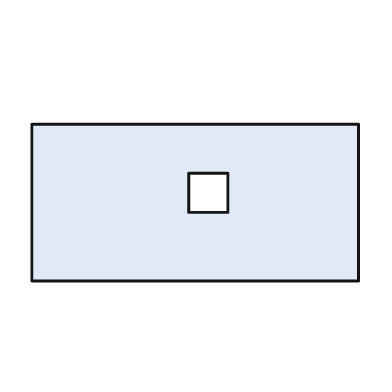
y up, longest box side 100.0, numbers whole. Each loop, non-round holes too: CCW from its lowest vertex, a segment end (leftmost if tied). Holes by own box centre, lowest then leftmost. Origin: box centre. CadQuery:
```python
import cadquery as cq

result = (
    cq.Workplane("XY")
    .moveTo(-50.0, -24.0)
    .lineTo(50.0, -24.0)
    .lineTo(50.0, 24.0)
    .lineTo(-50.0, 24.0)
    .close()
    .moveTo(-2.0, -3.0)
    .lineTo(10.0, -3.0)
    .lineTo(10.0, 9.0)
    .lineTo(-2.0, 9.0)
    .close()
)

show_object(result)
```